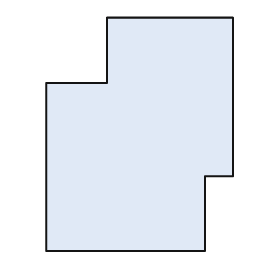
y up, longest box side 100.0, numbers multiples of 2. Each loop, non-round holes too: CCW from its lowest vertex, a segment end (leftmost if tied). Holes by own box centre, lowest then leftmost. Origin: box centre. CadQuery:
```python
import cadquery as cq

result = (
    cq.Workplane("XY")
    .moveTo(-40.0, -50.0)
    .lineTo(28.0, -50.0)
    .lineTo(28.0, -18.0)
    .lineTo(40.0, -18.0)
    .lineTo(40.0, 50.0)
    .lineTo(-14.0, 50.0)
    .lineTo(-14.0, 22.0)
    .lineTo(-40.0, 22.0)
    .close()
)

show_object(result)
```